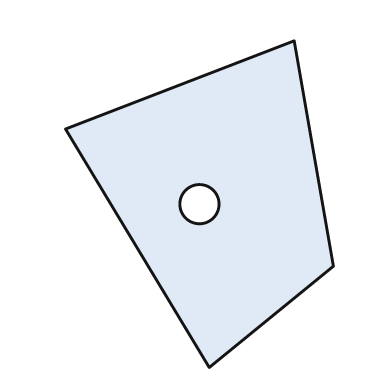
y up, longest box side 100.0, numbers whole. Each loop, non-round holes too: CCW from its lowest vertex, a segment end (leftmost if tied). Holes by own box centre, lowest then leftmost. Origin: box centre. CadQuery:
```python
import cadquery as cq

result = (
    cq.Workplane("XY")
    .moveTo(3.0, -50.0)
    .lineTo(41.0, -19.0)
    .lineTo(29.0, 50.0)
    .lineTo(-41.0, 23.0)
    .close()
    .moveTo(0.0, 0.0)
    .circle(6.0)
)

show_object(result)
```